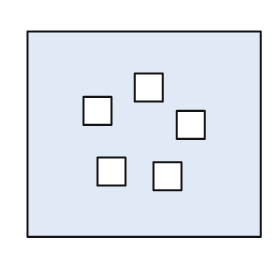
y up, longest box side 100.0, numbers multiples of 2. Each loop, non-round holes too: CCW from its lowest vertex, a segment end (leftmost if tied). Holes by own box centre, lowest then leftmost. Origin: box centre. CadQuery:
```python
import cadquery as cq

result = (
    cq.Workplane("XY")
    .moveTo(-50.0, -44.0)
    .lineTo(50.0, -44.0)
    .lineTo(50.0, 44.0)
    .lineTo(-50.0, 44.0)
    .close()
    .moveTo(4.0, -24.0)
    .lineTo(16.0, -24.0)
    .lineTo(16.0, -12.0)
    .lineTo(4.0, -12.0)
    .close()
    .moveTo(-20.0, -22.0)
    .lineTo(-8.0, -22.0)
    .lineTo(-8.0, -10.0)
    .lineTo(-20.0, -10.0)
    .close()
    .moveTo(14.0, -2.0)
    .lineTo(26.0, -2.0)
    .lineTo(26.0, 10.0)
    .lineTo(14.0, 10.0)
    .close()
    .moveTo(-26.0, 4.0)
    .lineTo(-14.0, 4.0)
    .lineTo(-14.0, 16.0)
    .lineTo(-26.0, 16.0)
    .close()
    .moveTo(-4.0, 14.0)
    .lineTo(8.0, 14.0)
    .lineTo(8.0, 26.0)
    .lineTo(-4.0, 26.0)
    .close()
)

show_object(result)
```